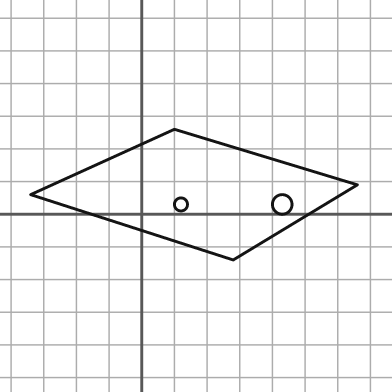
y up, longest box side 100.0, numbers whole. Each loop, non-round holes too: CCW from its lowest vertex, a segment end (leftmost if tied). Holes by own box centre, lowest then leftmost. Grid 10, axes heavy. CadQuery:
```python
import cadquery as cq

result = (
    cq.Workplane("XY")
    .moveTo(28.0, -14.0)
    .lineTo(66.0, 9.0)
    .lineTo(10.0, 26.0)
    .lineTo(-34.0, 6.0)
    .close()
    .moveTo(12.0, 3.0)
    .circle(2.0)
    .moveTo(43.0, 3.0)
    .circle(3.0)
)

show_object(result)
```